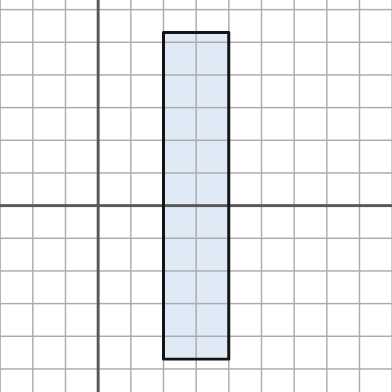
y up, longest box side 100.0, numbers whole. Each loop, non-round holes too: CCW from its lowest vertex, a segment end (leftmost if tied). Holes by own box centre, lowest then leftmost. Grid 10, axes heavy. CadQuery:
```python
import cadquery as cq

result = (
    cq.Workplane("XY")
    .moveTo(20.0, -47.0)
    .lineTo(40.0, -47.0)
    .lineTo(40.0, 53.0)
    .lineTo(20.0, 53.0)
    .close()
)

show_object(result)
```